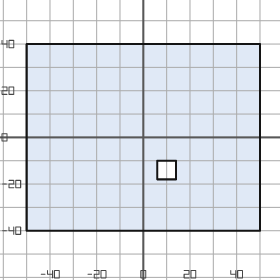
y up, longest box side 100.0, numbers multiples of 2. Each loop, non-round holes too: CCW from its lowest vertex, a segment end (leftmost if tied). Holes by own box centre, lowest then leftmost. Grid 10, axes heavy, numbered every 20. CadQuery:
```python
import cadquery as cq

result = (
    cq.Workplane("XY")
    .moveTo(-50.0, -40.0)
    .lineTo(50.0, -40.0)
    .lineTo(50.0, 40.0)
    .lineTo(-50.0, 40.0)
    .close()
    .moveTo(6.0, -18.0)
    .lineTo(14.0, -18.0)
    .lineTo(14.0, -10.0)
    .lineTo(6.0, -10.0)
    .close()
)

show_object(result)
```